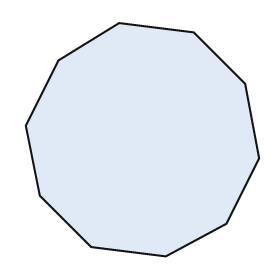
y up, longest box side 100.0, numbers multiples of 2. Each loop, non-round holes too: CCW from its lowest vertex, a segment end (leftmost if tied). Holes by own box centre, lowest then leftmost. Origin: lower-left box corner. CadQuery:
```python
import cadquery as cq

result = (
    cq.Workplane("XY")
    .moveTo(60.0, 0.0)
    .lineTo(86.0, 14.0)
    .lineTo(100.0, 42.0)
    .lineTo(94.0, 74.0)
    .lineTo(72.0, 96.0)
    .lineTo(40.0, 100.0)
    .lineTo(14.0, 84.0)
    .lineTo(0.0, 56.0)
    .lineTo(6.0, 26.0)
    .lineTo(28.0, 4.0)
    .close()
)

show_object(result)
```